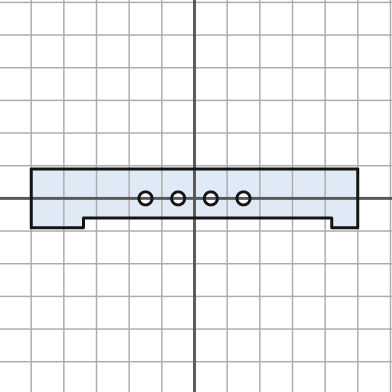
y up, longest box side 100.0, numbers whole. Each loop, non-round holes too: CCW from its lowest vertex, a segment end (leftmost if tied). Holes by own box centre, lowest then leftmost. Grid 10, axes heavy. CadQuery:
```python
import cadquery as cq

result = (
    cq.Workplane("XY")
    .moveTo(-50.0, -9.0)
    .lineTo(-34.0, -9.0)
    .lineTo(-34.0, -6.0)
    .lineTo(42.0, -6.0)
    .lineTo(42.0, -9.0)
    .lineTo(50.0, -9.0)
    .lineTo(50.0, 9.0)
    .lineTo(-50.0, 9.0)
    .close()
    .moveTo(-15.0, 0.0)
    .circle(2.0)
    .moveTo(-5.0, 0.0)
    .circle(2.0)
    .moveTo(5.0, 0.0)
    .circle(2.0)
    .moveTo(15.0, 0.0)
    .circle(2.0)
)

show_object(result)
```